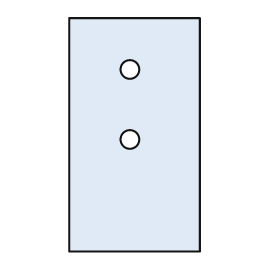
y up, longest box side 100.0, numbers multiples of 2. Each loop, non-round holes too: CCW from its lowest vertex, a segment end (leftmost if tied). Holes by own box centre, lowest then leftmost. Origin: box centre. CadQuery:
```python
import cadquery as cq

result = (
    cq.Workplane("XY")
    .moveTo(-28.0, -50.0)
    .lineTo(28.0, -50.0)
    .lineTo(28.0, 50.0)
    .lineTo(-28.0, 50.0)
    .close()
    .moveTo(-2.0, -2.0)
    .circle(4.0)
    .moveTo(-2.0, 28.0)
    .circle(4.0)
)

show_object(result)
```